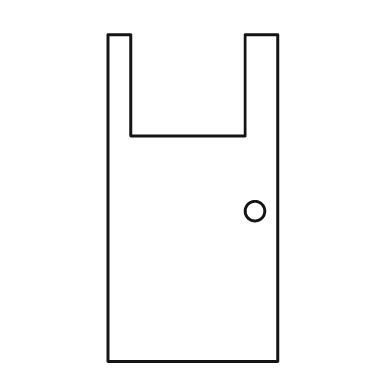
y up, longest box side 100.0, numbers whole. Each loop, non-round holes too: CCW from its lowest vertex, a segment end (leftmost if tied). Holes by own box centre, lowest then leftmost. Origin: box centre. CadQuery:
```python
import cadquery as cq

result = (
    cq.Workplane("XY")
    .moveTo(-26.0, -50.0)
    .lineTo(26.0, -50.0)
    .lineTo(26.0, 50.0)
    .lineTo(16.0, 50.0)
    .lineTo(16.0, 19.0)
    .lineTo(-19.0, 19.0)
    .lineTo(-19.0, 50.0)
    .lineTo(-26.0, 50.0)
    .close()
    .moveTo(19.0, -4.0)
    .circle(3.0)
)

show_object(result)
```